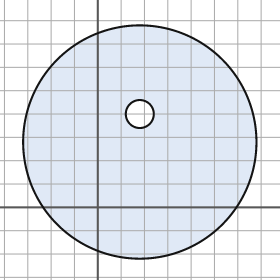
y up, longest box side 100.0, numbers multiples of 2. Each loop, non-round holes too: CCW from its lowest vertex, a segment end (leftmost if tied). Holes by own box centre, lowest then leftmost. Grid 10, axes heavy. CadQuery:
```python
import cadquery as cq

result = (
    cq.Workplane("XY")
    .moveTo(18.0, 28.0)
    .circle(50.0)
    .moveTo(18.0, 40.0)
    .circle(6.0)
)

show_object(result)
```